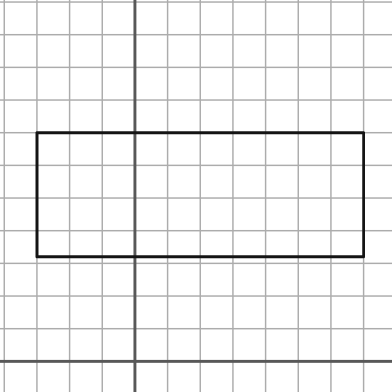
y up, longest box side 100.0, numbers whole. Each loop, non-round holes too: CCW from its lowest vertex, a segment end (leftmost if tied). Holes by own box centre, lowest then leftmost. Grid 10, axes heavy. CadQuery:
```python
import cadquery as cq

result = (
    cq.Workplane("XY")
    .moveTo(-30.0, 32.0)
    .lineTo(70.0, 32.0)
    .lineTo(70.0, 70.0)
    .lineTo(-30.0, 70.0)
    .close()
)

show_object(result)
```